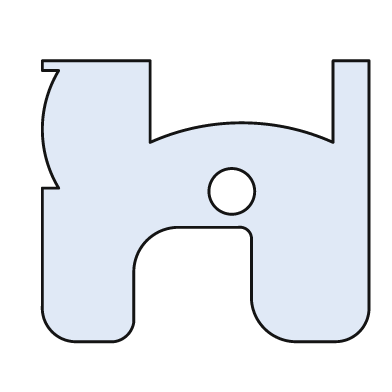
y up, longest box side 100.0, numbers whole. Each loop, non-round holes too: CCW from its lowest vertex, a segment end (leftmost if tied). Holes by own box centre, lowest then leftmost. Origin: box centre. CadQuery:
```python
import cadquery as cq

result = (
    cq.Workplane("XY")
    .moveTo(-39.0, -43.0)
    .lineTo(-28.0, -43.0)
    .threePointArc((-24.0, -41.0), (-22.0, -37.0))
    .lineTo(-22.0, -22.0)
    .threePointArc((-18.0, -12.0), (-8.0, -8.0))
    .lineTo(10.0, -8.0)
    .threePointArc((13.0, -9.0), (14.0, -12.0))
    .lineTo(14.0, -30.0)
    .threePointArc((18.0, -39.0), (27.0, -43.0))
    .lineTo(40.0, -43.0)
    .threePointArc((47.0, -40.0), (50.0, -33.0))
    .lineTo(50.0, 43.0)
    .lineTo(39.0, 43.0)
    .lineTo(39.0, 18.0)
    .threePointArc((11.0, 24.0), (-17.0, 18.0))
    .lineTo(-17.0, 43.0)
    .lineTo(-50.0, 43.0)
    .lineTo(-50.0, 40.0)
    .lineTo(-45.0, 40.0)
    .threePointArc((-50.0, 22.0), (-45.0, 4.0))
    .lineTo(-50.0, 4.0)
    .lineTo(-50.0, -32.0)
    .threePointArc((-47.0, -40.0), (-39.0, -43.0))
    .close()
    .moveTo(8.0, 3.0)
    .circle(7.0)
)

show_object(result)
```